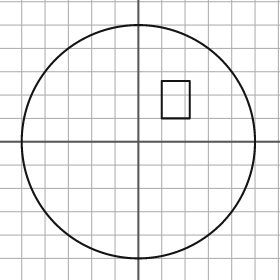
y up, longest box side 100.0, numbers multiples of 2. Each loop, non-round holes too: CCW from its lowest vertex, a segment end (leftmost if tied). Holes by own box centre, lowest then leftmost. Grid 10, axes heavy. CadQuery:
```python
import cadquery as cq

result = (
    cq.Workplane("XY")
    .moveTo(0.0, 0.0)
    .circle(50.0)
    .moveTo(10.0, 10.0)
    .lineTo(22.0, 10.0)
    .lineTo(22.0, 26.0)
    .lineTo(10.0, 26.0)
    .close()
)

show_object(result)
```